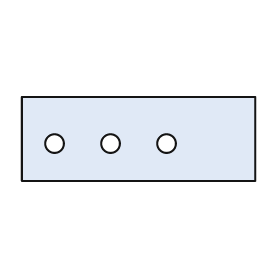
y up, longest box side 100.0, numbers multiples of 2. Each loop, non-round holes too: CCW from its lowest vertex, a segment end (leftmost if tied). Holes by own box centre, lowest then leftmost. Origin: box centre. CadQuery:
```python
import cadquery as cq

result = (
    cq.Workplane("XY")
    .moveTo(-50.0, -18.0)
    .lineTo(50.0, -18.0)
    .lineTo(50.0, 18.0)
    .lineTo(-50.0, 18.0)
    .close()
    .moveTo(-36.0, -2.0)
    .circle(4.0)
    .moveTo(-12.0, -2.0)
    .circle(4.0)
    .moveTo(12.0, -2.0)
    .circle(4.0)
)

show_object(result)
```